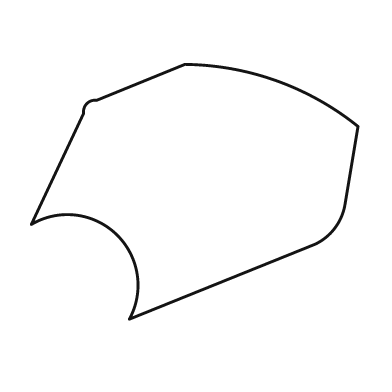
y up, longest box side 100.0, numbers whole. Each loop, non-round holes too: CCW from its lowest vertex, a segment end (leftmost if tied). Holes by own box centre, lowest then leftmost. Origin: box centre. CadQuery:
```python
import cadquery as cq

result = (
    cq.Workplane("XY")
    .moveTo(-20.0, -39.0)
    .lineTo(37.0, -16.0)
    .threePointArc((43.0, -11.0), (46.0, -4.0))
    .lineTo(50.0, 20.0)
    .threePointArc((25.0, 34.0), (-3.0, 39.0))
    .lineTo(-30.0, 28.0)
    .threePointArc((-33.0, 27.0), (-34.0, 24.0))
    .lineTo(-50.0, -10.0)
    .threePointArc((-24.0, -13.0), (-20.0, -39.0))
    .close()
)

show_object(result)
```